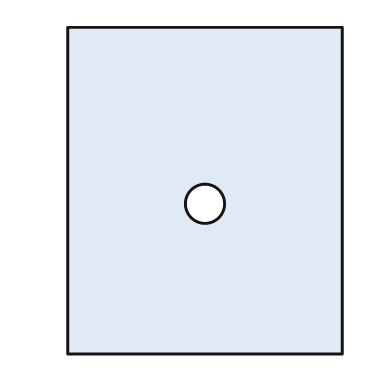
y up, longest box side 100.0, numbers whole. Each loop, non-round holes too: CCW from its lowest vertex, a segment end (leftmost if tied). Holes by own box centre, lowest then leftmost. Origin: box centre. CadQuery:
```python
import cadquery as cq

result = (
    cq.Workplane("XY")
    .moveTo(-42.0, -50.0)
    .lineTo(42.0, -50.0)
    .lineTo(42.0, 50.0)
    .lineTo(-42.0, 50.0)
    .close()
    .moveTo(0.0, -4.0)
    .circle(6.0)
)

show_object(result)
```